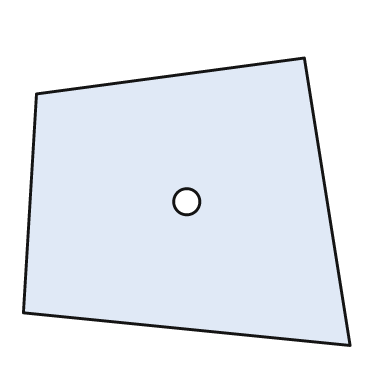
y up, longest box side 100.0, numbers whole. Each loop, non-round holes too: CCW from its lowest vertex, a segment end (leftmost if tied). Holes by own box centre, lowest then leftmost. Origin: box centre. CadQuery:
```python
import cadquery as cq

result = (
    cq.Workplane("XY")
    .moveTo(50.0, -44.0)
    .lineTo(36.0, 44.0)
    .lineTo(-46.0, 33.0)
    .lineTo(-50.0, -34.0)
    .close()
    .moveTo(0.0, 0.0)
    .circle(4.0)
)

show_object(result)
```